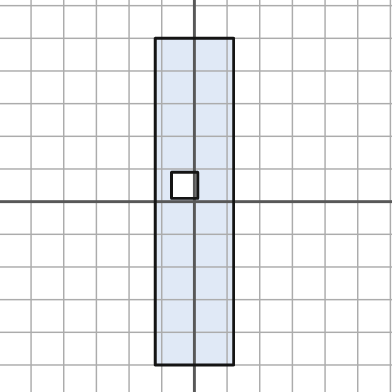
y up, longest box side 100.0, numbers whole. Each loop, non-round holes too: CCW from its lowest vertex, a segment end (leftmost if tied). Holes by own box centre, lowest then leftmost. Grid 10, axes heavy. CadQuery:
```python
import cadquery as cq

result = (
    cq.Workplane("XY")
    .moveTo(-12.0, -50.0)
    .lineTo(12.0, -50.0)
    .lineTo(12.0, 50.0)
    .lineTo(-12.0, 50.0)
    .close()
    .moveTo(-7.0, 1.0)
    .lineTo(1.0, 1.0)
    .lineTo(1.0, 9.0)
    .lineTo(-7.0, 9.0)
    .close()
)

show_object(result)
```